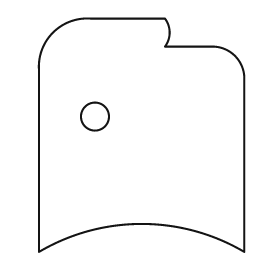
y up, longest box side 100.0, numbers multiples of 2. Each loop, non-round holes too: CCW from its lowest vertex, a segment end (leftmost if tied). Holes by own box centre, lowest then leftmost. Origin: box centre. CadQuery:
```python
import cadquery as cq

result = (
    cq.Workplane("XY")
    .moveTo(-44.0, -50.0)
    .threePointArc((0.0, -38.0), (44.0, -50.0))
    .lineTo(44.0, 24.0)
    .threePointArc((40.0, 34.0), (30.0, 38.0))
    .lineTo(10.0, 38.0)
    .threePointArc((12.0, 44.0), (10.0, 50.0))
    .lineTo(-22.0, 50.0)
    .threePointArc((-38.0, 44.0), (-44.0, 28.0))
    .close()
    .moveTo(-20.0, 8.0)
    .circle(6.0)
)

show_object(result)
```